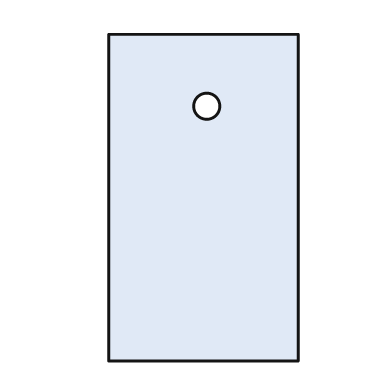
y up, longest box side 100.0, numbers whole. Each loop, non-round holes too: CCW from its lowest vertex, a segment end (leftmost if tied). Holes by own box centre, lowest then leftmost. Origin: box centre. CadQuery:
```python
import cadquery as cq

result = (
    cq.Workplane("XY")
    .moveTo(-29.0, -50.0)
    .lineTo(29.0, -50.0)
    .lineTo(29.0, 50.0)
    .lineTo(-29.0, 50.0)
    .close()
    .moveTo(1.0, 28.0)
    .circle(4.0)
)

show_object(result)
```